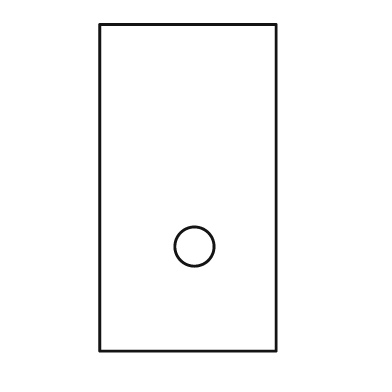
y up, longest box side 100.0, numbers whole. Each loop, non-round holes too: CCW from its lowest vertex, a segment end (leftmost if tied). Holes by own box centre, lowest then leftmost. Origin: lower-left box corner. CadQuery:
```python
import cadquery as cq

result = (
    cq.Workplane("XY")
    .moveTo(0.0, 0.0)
    .lineTo(54.0, 0.0)
    .lineTo(54.0, 100.0)
    .lineTo(0.0, 100.0)
    .close()
    .moveTo(29.0, 32.0)
    .circle(6.0)
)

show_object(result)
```